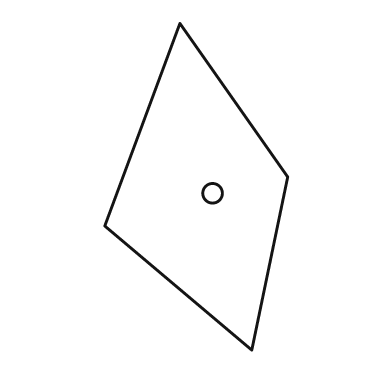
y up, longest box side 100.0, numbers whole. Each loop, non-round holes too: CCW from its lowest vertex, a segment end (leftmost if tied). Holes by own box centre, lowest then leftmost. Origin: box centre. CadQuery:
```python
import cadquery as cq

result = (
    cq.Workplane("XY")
    .moveTo(17.0, -50.0)
    .lineTo(28.0, 3.0)
    .lineTo(-5.0, 50.0)
    .lineTo(-28.0, -12.0)
    .close()
    .moveTo(5.0, -2.0)
    .circle(3.0)
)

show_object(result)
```